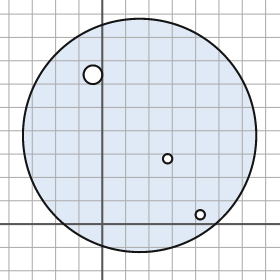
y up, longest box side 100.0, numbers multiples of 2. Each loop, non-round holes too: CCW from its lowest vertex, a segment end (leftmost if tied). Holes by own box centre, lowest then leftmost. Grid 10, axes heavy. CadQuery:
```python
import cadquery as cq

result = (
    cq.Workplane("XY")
    .moveTo(16.0, 38.0)
    .circle(50.0)
    .moveTo(42.0, 4.0)
    .circle(2.0)
    .moveTo(28.0, 28.0)
    .circle(2.0)
    .moveTo(-4.0, 64.0)
    .circle(4.0)
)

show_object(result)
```